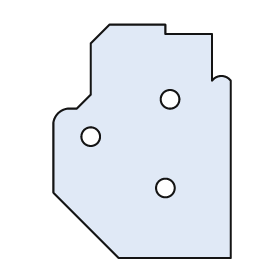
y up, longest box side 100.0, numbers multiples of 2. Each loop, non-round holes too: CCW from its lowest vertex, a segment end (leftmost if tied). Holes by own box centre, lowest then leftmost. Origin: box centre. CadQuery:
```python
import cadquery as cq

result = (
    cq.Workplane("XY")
    .moveTo(-10.0, -50.0)
    .lineTo(38.0, -50.0)
    .lineTo(38.0, 26.0)
    .threePointArc((34.0, 28.0), (30.0, 26.0))
    .lineTo(30.0, 46.0)
    .lineTo(10.0, 46.0)
    .lineTo(10.0, 50.0)
    .lineTo(-14.0, 50.0)
    .lineTo(-22.0, 42.0)
    .lineTo(-22.0, 20.0)
    .lineTo(-28.0, 14.0)
    .lineTo(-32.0, 14.0)
    .threePointArc((-36.0, 12.0), (-38.0, 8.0))
    .lineTo(-38.0, -22.0)
    .close()
    .moveTo(10.0, -20.0)
    .circle(4.0)
    .moveTo(-22.0, 2.0)
    .circle(4.0)
    .moveTo(12.0, 18.0)
    .circle(4.0)
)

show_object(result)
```